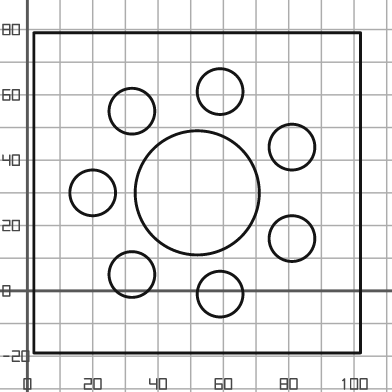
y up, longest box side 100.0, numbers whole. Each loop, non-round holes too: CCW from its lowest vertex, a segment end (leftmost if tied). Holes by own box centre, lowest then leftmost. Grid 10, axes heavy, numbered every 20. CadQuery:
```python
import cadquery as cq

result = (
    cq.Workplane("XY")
    .moveTo(2.0, -19.0)
    .lineTo(102.0, -19.0)
    .lineTo(102.0, 79.0)
    .lineTo(2.0, 79.0)
    .close()
    .moveTo(59.0, -1.0)
    .circle(7.0)
    .moveTo(32.0, 5.0)
    .circle(7.0)
    .moveTo(81.0, 16.0)
    .circle(7.0)
    .moveTo(20.0, 30.0)
    .circle(7.0)
    .moveTo(52.0, 30.0)
    .circle(19.0)
    .moveTo(81.0, 44.0)
    .circle(7.0)
    .moveTo(32.0, 55.0)
    .circle(7.0)
    .moveTo(59.0, 61.0)
    .circle(7.0)
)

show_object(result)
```